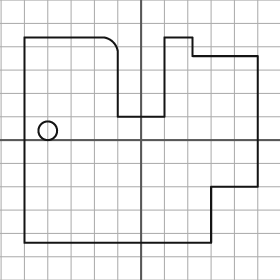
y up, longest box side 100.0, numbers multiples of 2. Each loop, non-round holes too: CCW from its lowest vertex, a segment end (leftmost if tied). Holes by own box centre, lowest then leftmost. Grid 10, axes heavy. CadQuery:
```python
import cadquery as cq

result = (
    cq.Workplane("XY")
    .moveTo(-50.0, -44.0)
    .lineTo(30.0, -44.0)
    .lineTo(30.0, -20.0)
    .lineTo(50.0, -20.0)
    .lineTo(50.0, 36.0)
    .lineTo(22.0, 36.0)
    .lineTo(22.0, 44.0)
    .lineTo(10.0, 44.0)
    .lineTo(10.0, 10.0)
    .lineTo(-10.0, 10.0)
    .lineTo(-10.0, 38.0)
    .threePointArc((-12.0, 42.0), (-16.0, 44.0))
    .lineTo(-50.0, 44.0)
    .close()
    .moveTo(-40.0, 4.0)
    .circle(4.0)
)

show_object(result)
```